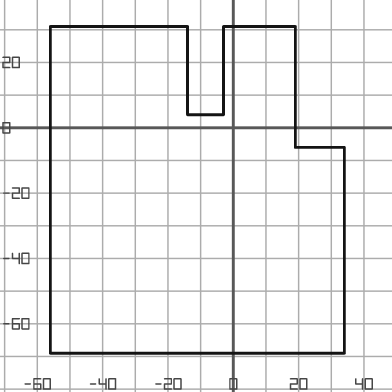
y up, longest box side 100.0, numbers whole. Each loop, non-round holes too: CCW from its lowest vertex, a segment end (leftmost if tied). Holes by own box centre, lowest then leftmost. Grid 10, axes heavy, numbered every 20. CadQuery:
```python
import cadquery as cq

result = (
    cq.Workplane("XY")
    .moveTo(-56.0, -69.0)
    .lineTo(34.0, -69.0)
    .lineTo(34.0, -6.0)
    .lineTo(19.0, -6.0)
    .lineTo(19.0, 31.0)
    .lineTo(-3.0, 31.0)
    .lineTo(-3.0, 4.0)
    .lineTo(-14.0, 4.0)
    .lineTo(-14.0, 31.0)
    .lineTo(-56.0, 31.0)
    .close()
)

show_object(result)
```